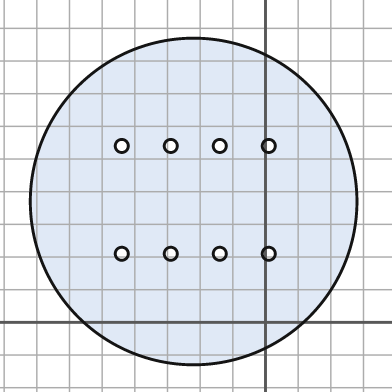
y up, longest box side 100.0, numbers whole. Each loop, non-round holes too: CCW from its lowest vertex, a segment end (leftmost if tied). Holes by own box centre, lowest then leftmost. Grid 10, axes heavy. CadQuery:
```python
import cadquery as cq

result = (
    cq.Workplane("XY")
    .moveTo(-22.0, 37.0)
    .circle(50.0)
    .moveTo(-44.0, 21.0)
    .circle(2.0)
    .moveTo(-29.0, 21.0)
    .circle(2.0)
    .moveTo(-14.0, 21.0)
    .circle(2.0)
    .moveTo(1.0, 21.0)
    .circle(2.0)
    .moveTo(-44.0, 54.0)
    .circle(2.0)
    .moveTo(-29.0, 54.0)
    .circle(2.0)
    .moveTo(-14.0, 54.0)
    .circle(2.0)
    .moveTo(1.0, 54.0)
    .circle(2.0)
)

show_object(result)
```